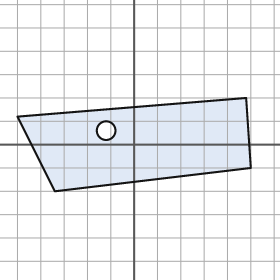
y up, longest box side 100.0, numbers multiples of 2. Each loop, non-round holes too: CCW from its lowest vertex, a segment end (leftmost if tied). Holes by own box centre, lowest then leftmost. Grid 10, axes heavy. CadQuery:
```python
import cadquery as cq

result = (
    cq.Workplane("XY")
    .moveTo(-34.0, -20.0)
    .lineTo(50.0, -10.0)
    .lineTo(48.0, 20.0)
    .lineTo(-50.0, 12.0)
    .close()
    .moveTo(-12.0, 6.0)
    .circle(4.0)
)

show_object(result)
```